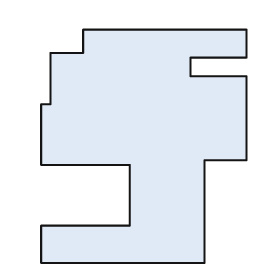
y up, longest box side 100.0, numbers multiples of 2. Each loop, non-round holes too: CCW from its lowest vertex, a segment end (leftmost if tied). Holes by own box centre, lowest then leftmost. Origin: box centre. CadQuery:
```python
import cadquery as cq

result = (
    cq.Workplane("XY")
    .moveTo(-44.0, -50.0)
    .lineTo(26.0, -50.0)
    .lineTo(26.0, -6.0)
    .lineTo(44.0, -6.0)
    .lineTo(44.0, 30.0)
    .lineTo(20.0, 30.0)
    .lineTo(20.0, 38.0)
    .lineTo(44.0, 38.0)
    .lineTo(44.0, 50.0)
    .lineTo(-26.0, 50.0)
    .lineTo(-26.0, 40.0)
    .lineTo(-40.0, 40.0)
    .lineTo(-40.0, 18.0)
    .lineTo(-44.0, 18.0)
    .lineTo(-44.0, -8.0)
    .lineTo(-6.0, -8.0)
    .lineTo(-6.0, -34.0)
    .lineTo(-44.0, -34.0)
    .close()
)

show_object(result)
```